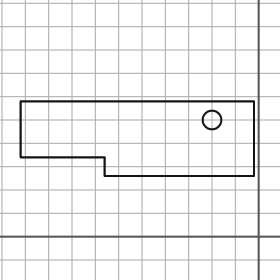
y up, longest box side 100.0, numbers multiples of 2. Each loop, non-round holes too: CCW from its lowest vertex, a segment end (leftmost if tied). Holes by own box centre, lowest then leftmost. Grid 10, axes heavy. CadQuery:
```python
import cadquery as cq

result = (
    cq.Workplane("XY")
    .moveTo(-66.0, 26.0)
    .lineTo(-2.0, 26.0)
    .lineTo(-2.0, 58.0)
    .lineTo(-102.0, 58.0)
    .lineTo(-102.0, 34.0)
    .lineTo(-66.0, 34.0)
    .close()
    .moveTo(-20.0, 50.0)
    .circle(4.0)
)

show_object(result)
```